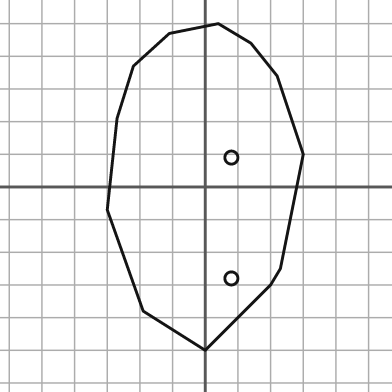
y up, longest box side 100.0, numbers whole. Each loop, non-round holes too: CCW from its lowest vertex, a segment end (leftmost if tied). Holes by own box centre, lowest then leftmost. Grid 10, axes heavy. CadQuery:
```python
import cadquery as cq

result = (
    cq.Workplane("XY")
    .moveTo(0.0, -50.0)
    .lineTo(20.0, -30.0)
    .lineTo(23.0, -25.0)
    .lineTo(30.0, 10.0)
    .lineTo(22.0, 34.0)
    .lineTo(14.0, 44.0)
    .lineTo(4.0, 50.0)
    .lineTo(-11.0, 47.0)
    .lineTo(-22.0, 37.0)
    .lineTo(-27.0, 21.0)
    .lineTo(-30.0, -7.0)
    .lineTo(-19.0, -38.0)
    .close()
    .moveTo(8.0, -28.0)
    .circle(2.0)
    .moveTo(8.0, 9.0)
    .circle(2.0)
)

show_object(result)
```